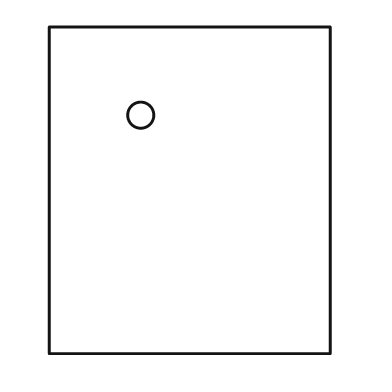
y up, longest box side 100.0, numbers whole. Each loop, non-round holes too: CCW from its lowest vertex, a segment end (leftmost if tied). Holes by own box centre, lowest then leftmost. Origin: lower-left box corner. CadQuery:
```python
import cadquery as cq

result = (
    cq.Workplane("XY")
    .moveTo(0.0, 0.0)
    .lineTo(86.0, 0.0)
    .lineTo(86.0, 100.0)
    .lineTo(0.0, 100.0)
    .close()
    .moveTo(28.0, 73.0)
    .circle(4.0)
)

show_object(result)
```